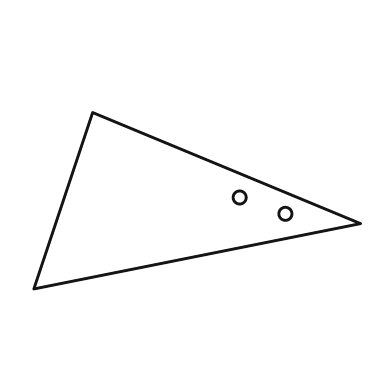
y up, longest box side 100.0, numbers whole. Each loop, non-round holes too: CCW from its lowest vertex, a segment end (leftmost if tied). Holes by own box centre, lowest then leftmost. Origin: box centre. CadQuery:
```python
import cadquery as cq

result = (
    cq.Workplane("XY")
    .moveTo(-50.0, -27.0)
    .lineTo(50.0, -7.0)
    .lineTo(-32.0, 27.0)
    .close()
    .moveTo(27.0, -4.0)
    .circle(2.0)
    .moveTo(13.0, 1.0)
    .circle(2.0)
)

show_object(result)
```